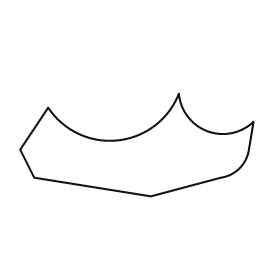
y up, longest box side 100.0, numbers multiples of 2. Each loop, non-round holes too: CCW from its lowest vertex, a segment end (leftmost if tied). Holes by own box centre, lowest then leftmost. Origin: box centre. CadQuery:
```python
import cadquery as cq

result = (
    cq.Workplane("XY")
    .moveTo(6.0, -22.0)
    .lineTo(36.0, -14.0)
    .threePointArc((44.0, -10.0), (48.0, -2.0))
    .lineTo(50.0, 10.0)
    .threePointArc((30.0, 6.0), (18.0, 22.0))
    .threePointArc((-8.0, 2.0), (-38.0, 16.0))
    .lineTo(-50.0, -2.0)
    .lineTo(-44.0, -14.0)
    .close()
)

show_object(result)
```